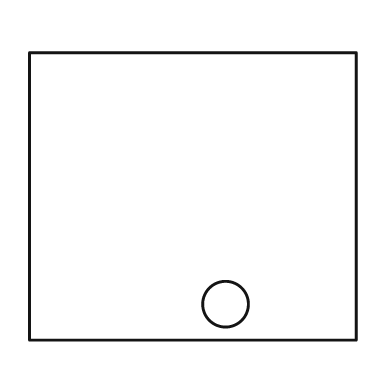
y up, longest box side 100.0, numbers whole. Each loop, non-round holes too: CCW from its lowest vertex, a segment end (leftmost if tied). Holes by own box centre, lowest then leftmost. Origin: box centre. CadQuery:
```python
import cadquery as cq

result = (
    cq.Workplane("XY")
    .moveTo(-50.0, -44.0)
    .lineTo(50.0, -44.0)
    .lineTo(50.0, 44.0)
    .lineTo(-50.0, 44.0)
    .close()
    .moveTo(10.0, -33.0)
    .circle(7.0)
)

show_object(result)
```